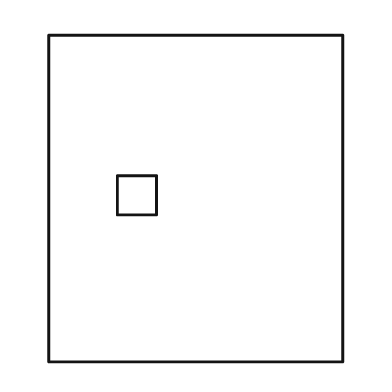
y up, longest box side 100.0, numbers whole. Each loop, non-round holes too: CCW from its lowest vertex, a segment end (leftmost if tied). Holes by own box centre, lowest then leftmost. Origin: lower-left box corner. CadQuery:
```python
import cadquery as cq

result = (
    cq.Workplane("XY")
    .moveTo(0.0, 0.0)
    .lineTo(90.0, 0.0)
    .lineTo(90.0, 100.0)
    .lineTo(0.0, 100.0)
    .close()
    .moveTo(21.0, 45.0)
    .lineTo(33.0, 45.0)
    .lineTo(33.0, 57.0)
    .lineTo(21.0, 57.0)
    .close()
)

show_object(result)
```